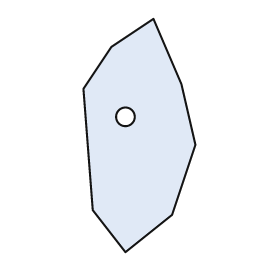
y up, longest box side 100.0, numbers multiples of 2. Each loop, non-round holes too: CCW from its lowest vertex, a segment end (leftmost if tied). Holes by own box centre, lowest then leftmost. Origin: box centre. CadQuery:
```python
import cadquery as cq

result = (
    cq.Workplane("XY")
    .moveTo(-6.0, -50.0)
    .lineTo(14.0, -34.0)
    .lineTo(24.0, -4.0)
    .lineTo(18.0, 22.0)
    .lineTo(6.0, 50.0)
    .lineTo(-12.0, 38.0)
    .lineTo(-24.0, 20.0)
    .lineTo(-20.0, -32.0)
    .close()
    .moveTo(-6.0, 8.0)
    .circle(4.0)
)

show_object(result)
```